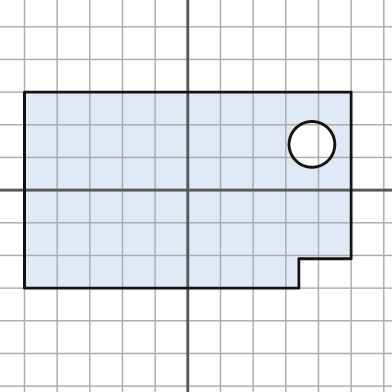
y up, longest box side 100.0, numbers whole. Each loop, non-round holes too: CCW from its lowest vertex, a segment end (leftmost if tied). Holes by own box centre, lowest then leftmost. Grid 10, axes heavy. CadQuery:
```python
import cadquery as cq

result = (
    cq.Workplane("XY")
    .moveTo(-50.0, -30.0)
    .lineTo(34.0, -30.0)
    .lineTo(34.0, -21.0)
    .lineTo(50.0, -21.0)
    .lineTo(50.0, 30.0)
    .lineTo(-50.0, 30.0)
    .close()
    .moveTo(38.0, 14.0)
    .circle(7.0)
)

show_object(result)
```